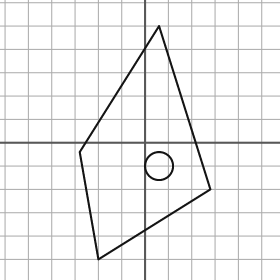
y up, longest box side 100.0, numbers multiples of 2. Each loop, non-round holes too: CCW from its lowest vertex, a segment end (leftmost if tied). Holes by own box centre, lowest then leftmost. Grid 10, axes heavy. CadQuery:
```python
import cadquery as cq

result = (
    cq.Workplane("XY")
    .moveTo(-20.0, -50.0)
    .lineTo(28.0, -20.0)
    .lineTo(6.0, 50.0)
    .lineTo(-28.0, -4.0)
    .close()
    .moveTo(6.0, -10.0)
    .circle(6.0)
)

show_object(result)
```